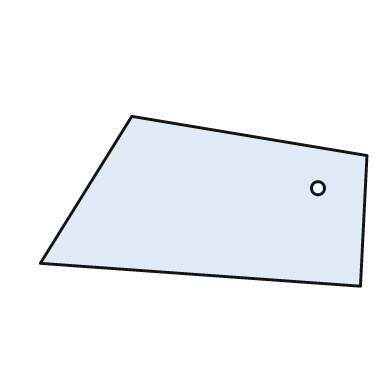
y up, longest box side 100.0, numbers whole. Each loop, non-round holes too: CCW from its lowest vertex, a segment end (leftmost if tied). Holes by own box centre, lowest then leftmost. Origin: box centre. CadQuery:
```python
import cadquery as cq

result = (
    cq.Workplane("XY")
    .moveTo(48.0, -26.0)
    .lineTo(50.0, 14.0)
    .lineTo(-22.0, 26.0)
    .lineTo(-50.0, -19.0)
    .close()
    .moveTo(35.0, 4.0)
    .circle(2.0)
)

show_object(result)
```